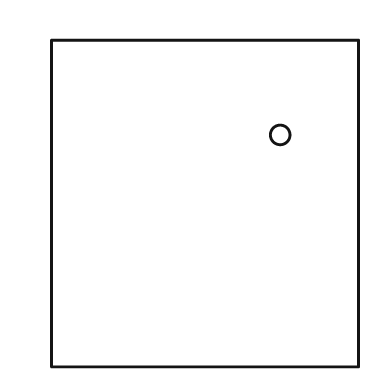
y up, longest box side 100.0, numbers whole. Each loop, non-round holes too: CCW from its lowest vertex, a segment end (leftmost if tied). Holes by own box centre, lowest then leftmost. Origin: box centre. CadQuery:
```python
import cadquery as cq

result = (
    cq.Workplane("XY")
    .moveTo(-47.0, -50.0)
    .lineTo(47.0, -50.0)
    .lineTo(47.0, 50.0)
    .lineTo(-47.0, 50.0)
    .close()
    .moveTo(23.0, 21.0)
    .circle(3.0)
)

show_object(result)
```